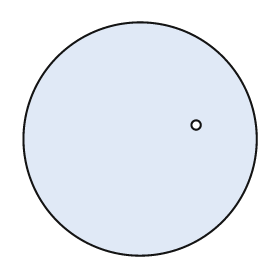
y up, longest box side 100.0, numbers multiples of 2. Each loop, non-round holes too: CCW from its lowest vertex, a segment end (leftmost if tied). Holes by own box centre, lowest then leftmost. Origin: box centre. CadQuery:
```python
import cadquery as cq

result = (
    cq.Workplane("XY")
    .moveTo(0.0, 0.0)
    .circle(50.0)
    .moveTo(24.0, 6.0)
    .circle(2.0)
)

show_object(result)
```